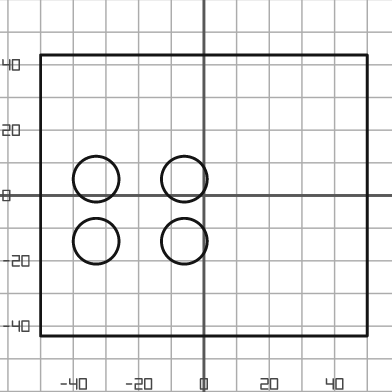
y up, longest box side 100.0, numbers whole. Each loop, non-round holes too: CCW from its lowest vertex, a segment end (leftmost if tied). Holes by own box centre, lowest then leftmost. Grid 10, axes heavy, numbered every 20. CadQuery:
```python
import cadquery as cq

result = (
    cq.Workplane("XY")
    .moveTo(-50.0, -43.0)
    .lineTo(50.0, -43.0)
    .lineTo(50.0, 43.0)
    .lineTo(-50.0, 43.0)
    .close()
    .moveTo(-33.0, -14.0)
    .circle(7.0)
    .moveTo(-6.0, -14.0)
    .circle(7.0)
    .moveTo(-33.0, 5.0)
    .circle(7.0)
    .moveTo(-6.0, 5.0)
    .circle(7.0)
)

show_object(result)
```